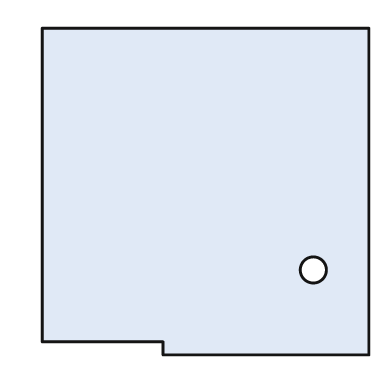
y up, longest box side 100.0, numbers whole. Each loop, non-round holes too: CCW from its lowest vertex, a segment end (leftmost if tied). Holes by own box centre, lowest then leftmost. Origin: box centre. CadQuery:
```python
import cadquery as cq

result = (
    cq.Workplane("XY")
    .moveTo(-13.0, -50.0)
    .lineTo(50.0, -50.0)
    .lineTo(50.0, 50.0)
    .lineTo(-50.0, 50.0)
    .lineTo(-50.0, -46.0)
    .lineTo(-13.0, -46.0)
    .close()
    .moveTo(33.0, -24.0)
    .circle(4.0)
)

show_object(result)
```